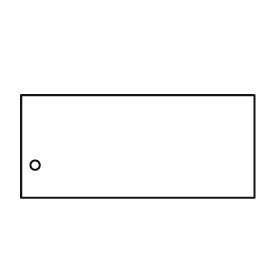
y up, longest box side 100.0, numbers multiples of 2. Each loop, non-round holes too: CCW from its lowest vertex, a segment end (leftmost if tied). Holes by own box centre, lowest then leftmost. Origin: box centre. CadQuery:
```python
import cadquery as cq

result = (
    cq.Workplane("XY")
    .moveTo(-50.0, -22.0)
    .lineTo(50.0, -22.0)
    .lineTo(50.0, 22.0)
    .lineTo(-50.0, 22.0)
    .close()
    .moveTo(-44.0, -8.0)
    .circle(2.0)
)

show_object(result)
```